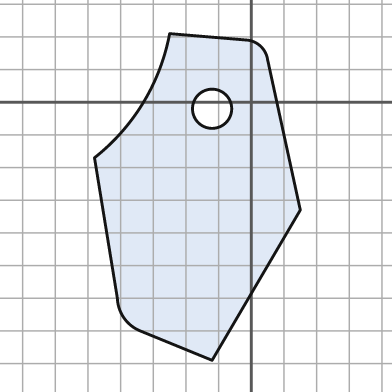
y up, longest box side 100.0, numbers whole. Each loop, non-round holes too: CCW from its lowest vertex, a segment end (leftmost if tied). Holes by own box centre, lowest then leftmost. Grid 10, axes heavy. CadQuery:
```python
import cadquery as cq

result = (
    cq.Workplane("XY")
    .moveTo(-12.0, -79.0)
    .lineTo(15.0, -33.0)
    .lineTo(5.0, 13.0)
    .threePointArc((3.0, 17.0), (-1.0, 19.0))
    .lineTo(-25.0, 21.0)
    .threePointArc((-33.0, 0.0), (-48.0, -17.0))
    .lineTo(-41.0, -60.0)
    .threePointArc((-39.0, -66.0), (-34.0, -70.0))
    .close()
    .moveTo(-12.0, -2.0)
    .circle(6.0)
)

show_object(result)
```